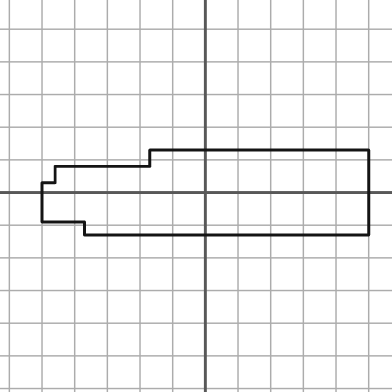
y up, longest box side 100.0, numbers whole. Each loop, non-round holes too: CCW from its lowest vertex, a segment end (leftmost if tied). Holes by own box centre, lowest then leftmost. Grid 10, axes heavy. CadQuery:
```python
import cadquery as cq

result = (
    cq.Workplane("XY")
    .moveTo(-37.0, -13.0)
    .lineTo(50.0, -13.0)
    .lineTo(50.0, 13.0)
    .lineTo(-17.0, 13.0)
    .lineTo(-17.0, 8.0)
    .lineTo(-46.0, 8.0)
    .lineTo(-46.0, 3.0)
    .lineTo(-50.0, 3.0)
    .lineTo(-50.0, -9.0)
    .lineTo(-37.0, -9.0)
    .close()
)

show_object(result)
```